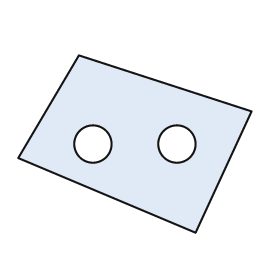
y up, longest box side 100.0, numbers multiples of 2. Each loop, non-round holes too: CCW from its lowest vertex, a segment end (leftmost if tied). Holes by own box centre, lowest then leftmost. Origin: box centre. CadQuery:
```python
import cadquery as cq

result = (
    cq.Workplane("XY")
    .moveTo(26.0, -38.0)
    .lineTo(50.0, 14.0)
    .lineTo(-24.0, 38.0)
    .lineTo(-50.0, -6.0)
    .close()
    .moveTo(-18.0, 0.0)
    .circle(8.0)
    .moveTo(18.0, 0.0)
    .circle(8.0)
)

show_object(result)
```